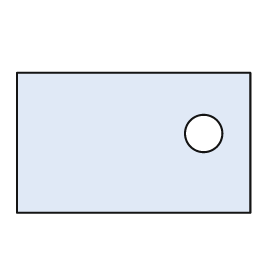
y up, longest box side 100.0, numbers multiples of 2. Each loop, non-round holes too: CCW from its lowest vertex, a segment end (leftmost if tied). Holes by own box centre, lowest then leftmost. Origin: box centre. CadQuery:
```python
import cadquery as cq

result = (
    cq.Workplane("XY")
    .moveTo(-50.0, -30.0)
    .lineTo(50.0, -30.0)
    .lineTo(50.0, 30.0)
    .lineTo(-50.0, 30.0)
    .close()
    .moveTo(30.0, 4.0)
    .circle(8.0)
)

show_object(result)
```